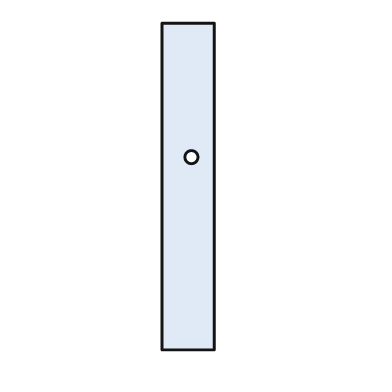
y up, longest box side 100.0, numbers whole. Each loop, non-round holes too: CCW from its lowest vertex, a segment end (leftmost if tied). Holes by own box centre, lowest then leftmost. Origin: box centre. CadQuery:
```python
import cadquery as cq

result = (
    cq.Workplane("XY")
    .moveTo(-8.0, -50.0)
    .lineTo(8.0, -50.0)
    .lineTo(8.0, 50.0)
    .lineTo(-8.0, 50.0)
    .close()
    .moveTo(1.0, 9.0)
    .circle(2.0)
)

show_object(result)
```